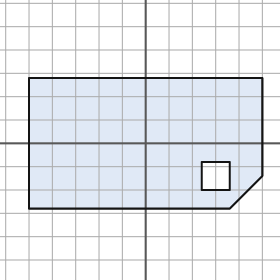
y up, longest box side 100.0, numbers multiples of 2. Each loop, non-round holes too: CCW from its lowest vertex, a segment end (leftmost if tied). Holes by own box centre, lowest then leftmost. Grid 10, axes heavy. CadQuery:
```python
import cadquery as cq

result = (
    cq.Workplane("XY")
    .moveTo(-50.0, -28.0)
    .lineTo(36.0, -28.0)
    .lineTo(50.0, -14.0)
    .lineTo(50.0, 28.0)
    .lineTo(-50.0, 28.0)
    .close()
    .moveTo(24.0, -20.0)
    .lineTo(36.0, -20.0)
    .lineTo(36.0, -8.0)
    .lineTo(24.0, -8.0)
    .close()
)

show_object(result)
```